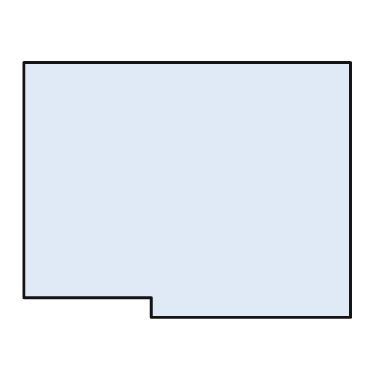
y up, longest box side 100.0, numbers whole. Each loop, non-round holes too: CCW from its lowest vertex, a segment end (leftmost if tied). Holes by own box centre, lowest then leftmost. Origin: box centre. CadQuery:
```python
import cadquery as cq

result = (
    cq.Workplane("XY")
    .moveTo(-11.0, -39.0)
    .lineTo(50.0, -39.0)
    .lineTo(50.0, 39.0)
    .lineTo(-50.0, 39.0)
    .lineTo(-50.0, -33.0)
    .lineTo(-11.0, -33.0)
    .close()
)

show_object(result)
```